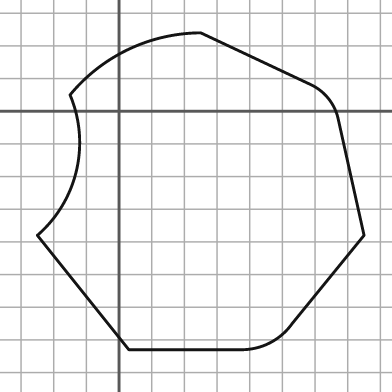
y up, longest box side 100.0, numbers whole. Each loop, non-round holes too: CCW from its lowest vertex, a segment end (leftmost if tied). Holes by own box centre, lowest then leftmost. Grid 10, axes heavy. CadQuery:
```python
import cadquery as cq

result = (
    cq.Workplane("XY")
    .moveTo(3.0, -73.0)
    .lineTo(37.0, -73.0)
    .threePointArc((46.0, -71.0), (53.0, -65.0))
    .lineTo(75.0, -38.0)
    .lineTo(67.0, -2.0)
    .threePointArc((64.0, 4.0), (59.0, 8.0))
    .lineTo(25.0, 24.0)
    .threePointArc((3.0, 19.0), (-15.0, 5.0))
    .threePointArc((-13.0, -18.0), (-25.0, -38.0))
    .close()
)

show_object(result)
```